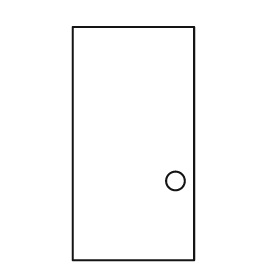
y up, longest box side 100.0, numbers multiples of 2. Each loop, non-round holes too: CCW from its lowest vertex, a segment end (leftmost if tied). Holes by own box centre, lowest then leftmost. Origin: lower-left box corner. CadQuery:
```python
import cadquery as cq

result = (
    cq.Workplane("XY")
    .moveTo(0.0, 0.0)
    .lineTo(52.0, 0.0)
    .lineTo(52.0, 100.0)
    .lineTo(0.0, 100.0)
    .close()
    .moveTo(44.0, 34.0)
    .circle(4.0)
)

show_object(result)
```